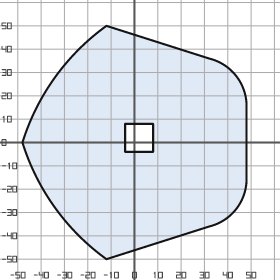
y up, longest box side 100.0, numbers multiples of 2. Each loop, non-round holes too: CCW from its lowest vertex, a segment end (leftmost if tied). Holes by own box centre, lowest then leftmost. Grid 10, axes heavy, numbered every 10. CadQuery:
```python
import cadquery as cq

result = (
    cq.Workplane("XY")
    .moveTo(-12.0, -50.0)
    .lineTo(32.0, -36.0)
    .threePointArc((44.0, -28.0), (48.0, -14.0))
    .lineTo(48.0, 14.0)
    .threePointArc((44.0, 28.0), (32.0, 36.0))
    .lineTo(-12.0, 50.0)
    .threePointArc((-34.0, 28.0), (-48.0, 0.0))
    .threePointArc((-34.0, -28.0), (-12.0, -50.0))
    .close()
    .moveTo(-4.0, -4.0)
    .lineTo(8.0, -4.0)
    .lineTo(8.0, 8.0)
    .lineTo(-4.0, 8.0)
    .close()
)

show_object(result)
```